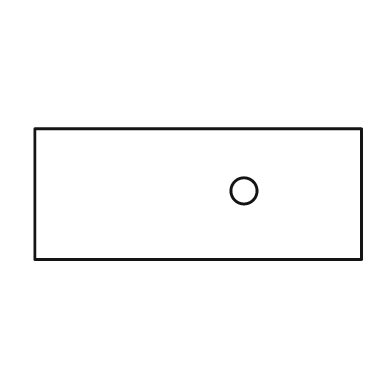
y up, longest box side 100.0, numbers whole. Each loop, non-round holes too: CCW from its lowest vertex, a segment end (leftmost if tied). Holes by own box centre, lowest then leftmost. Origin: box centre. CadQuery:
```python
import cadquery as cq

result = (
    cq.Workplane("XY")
    .moveTo(-50.0, -20.0)
    .lineTo(50.0, -20.0)
    .lineTo(50.0, 20.0)
    .lineTo(-50.0, 20.0)
    .close()
    .moveTo(14.0, 1.0)
    .circle(4.0)
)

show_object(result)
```